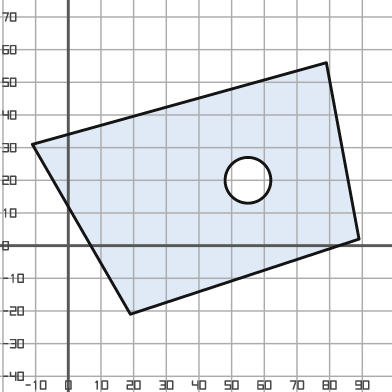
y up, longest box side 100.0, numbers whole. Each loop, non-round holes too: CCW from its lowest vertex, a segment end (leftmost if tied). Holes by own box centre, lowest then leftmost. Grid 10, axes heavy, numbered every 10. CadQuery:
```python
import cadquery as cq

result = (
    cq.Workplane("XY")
    .moveTo(19.0, -21.0)
    .lineTo(89.0, 2.0)
    .lineTo(79.0, 56.0)
    .lineTo(-11.0, 31.0)
    .close()
    .moveTo(55.0, 20.0)
    .circle(7.0)
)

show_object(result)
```